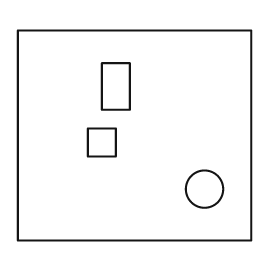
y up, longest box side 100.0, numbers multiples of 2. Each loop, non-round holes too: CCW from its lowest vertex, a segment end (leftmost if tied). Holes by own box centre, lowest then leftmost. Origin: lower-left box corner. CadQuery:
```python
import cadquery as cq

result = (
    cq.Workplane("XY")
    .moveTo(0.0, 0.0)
    .lineTo(100.0, 0.0)
    .lineTo(100.0, 90.0)
    .lineTo(0.0, 90.0)
    .close()
    .moveTo(80.0, 22.0)
    .circle(8.0)
    .moveTo(30.0, 36.0)
    .lineTo(42.0, 36.0)
    .lineTo(42.0, 48.0)
    .lineTo(30.0, 48.0)
    .close()
    .moveTo(36.0, 56.0)
    .lineTo(48.0, 56.0)
    .lineTo(48.0, 76.0)
    .lineTo(36.0, 76.0)
    .close()
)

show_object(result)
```